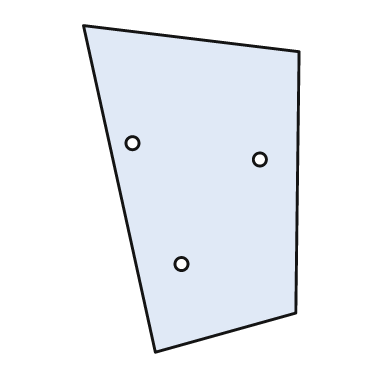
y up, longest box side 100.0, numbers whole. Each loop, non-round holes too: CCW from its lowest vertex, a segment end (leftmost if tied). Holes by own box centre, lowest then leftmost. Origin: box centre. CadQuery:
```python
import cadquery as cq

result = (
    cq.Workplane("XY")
    .moveTo(-11.0, -50.0)
    .lineTo(32.0, -38.0)
    .lineTo(33.0, 42.0)
    .lineTo(-33.0, 50.0)
    .close()
    .moveTo(-3.0, -23.0)
    .circle(2.0)
    .moveTo(21.0, 9.0)
    .circle(2.0)
    .moveTo(-18.0, 14.0)
    .circle(2.0)
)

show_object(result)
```